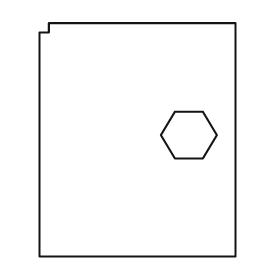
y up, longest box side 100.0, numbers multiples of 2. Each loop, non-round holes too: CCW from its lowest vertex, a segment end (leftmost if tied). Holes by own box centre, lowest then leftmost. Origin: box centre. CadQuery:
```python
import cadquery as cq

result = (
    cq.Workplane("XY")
    .moveTo(-42.0, -50.0)
    .lineTo(42.0, -50.0)
    .lineTo(42.0, 50.0)
    .lineTo(-38.0, 50.0)
    .lineTo(-38.0, 46.0)
    .lineTo(-42.0, 46.0)
    .close()
    .moveTo(16.0, -8.0)
    .lineTo(28.0, -8.0)
    .lineTo(34.0, 2.0)
    .lineTo(28.0, 12.0)
    .lineTo(16.0, 12.0)
    .lineTo(10.0, 2.0)
    .close()
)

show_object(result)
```